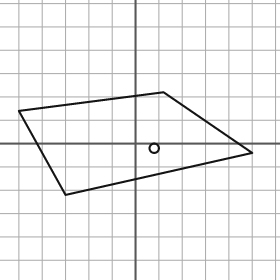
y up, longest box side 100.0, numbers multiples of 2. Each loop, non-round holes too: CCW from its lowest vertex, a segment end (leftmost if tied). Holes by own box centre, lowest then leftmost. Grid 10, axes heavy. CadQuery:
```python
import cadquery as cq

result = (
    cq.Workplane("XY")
    .moveTo(-30.0, -22.0)
    .lineTo(50.0, -4.0)
    .lineTo(12.0, 22.0)
    .lineTo(-50.0, 14.0)
    .close()
    .moveTo(8.0, -2.0)
    .circle(2.0)
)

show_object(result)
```